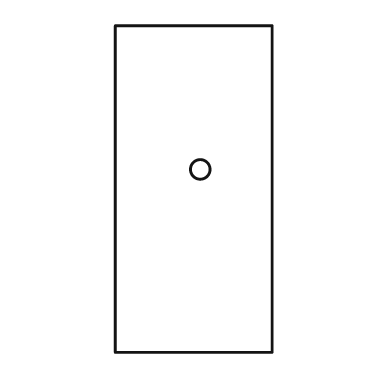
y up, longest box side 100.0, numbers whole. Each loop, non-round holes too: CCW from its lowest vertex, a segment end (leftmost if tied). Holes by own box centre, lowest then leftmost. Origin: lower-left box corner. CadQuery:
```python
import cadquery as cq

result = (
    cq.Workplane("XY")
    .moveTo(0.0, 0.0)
    .lineTo(48.0, 0.0)
    .lineTo(48.0, 100.0)
    .lineTo(0.0, 100.0)
    .close()
    .moveTo(26.0, 56.0)
    .circle(3.0)
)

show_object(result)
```